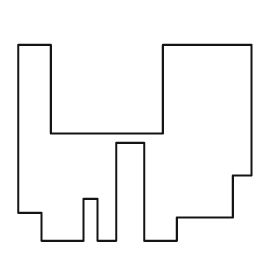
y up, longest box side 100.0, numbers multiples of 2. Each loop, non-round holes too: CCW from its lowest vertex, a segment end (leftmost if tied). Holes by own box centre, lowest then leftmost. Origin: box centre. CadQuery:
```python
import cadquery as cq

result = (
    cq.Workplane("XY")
    .moveTo(-40.0, -42.0)
    .lineTo(-22.0, -42.0)
    .lineTo(-22.0, -24.0)
    .lineTo(-16.0, -24.0)
    .lineTo(-16.0, -42.0)
    .lineTo(-8.0, -42.0)
    .lineTo(-8.0, 0.0)
    .lineTo(4.0, 0.0)
    .lineTo(4.0, -42.0)
    .lineTo(18.0, -42.0)
    .lineTo(18.0, -32.0)
    .lineTo(42.0, -32.0)
    .lineTo(42.0, -14.0)
    .lineTo(50.0, -14.0)
    .lineTo(50.0, 42.0)
    .lineTo(12.0, 42.0)
    .lineTo(12.0, 4.0)
    .lineTo(-36.0, 4.0)
    .lineTo(-36.0, 42.0)
    .lineTo(-50.0, 42.0)
    .lineTo(-50.0, -30.0)
    .lineTo(-40.0, -30.0)
    .close()
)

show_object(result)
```